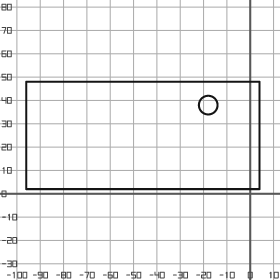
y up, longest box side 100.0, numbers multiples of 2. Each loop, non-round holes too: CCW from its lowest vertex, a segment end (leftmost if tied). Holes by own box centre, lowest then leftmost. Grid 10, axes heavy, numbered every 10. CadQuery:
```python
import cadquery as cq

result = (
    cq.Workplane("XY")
    .moveTo(-96.0, 2.0)
    .lineTo(4.0, 2.0)
    .lineTo(4.0, 48.0)
    .lineTo(-96.0, 48.0)
    .close()
    .moveTo(-18.0, 38.0)
    .circle(4.0)
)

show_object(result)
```